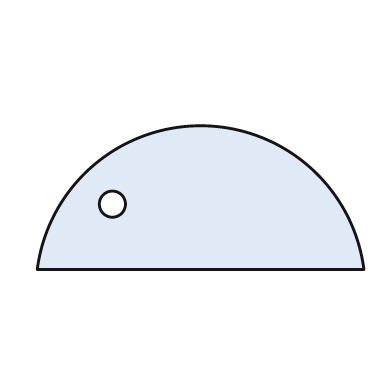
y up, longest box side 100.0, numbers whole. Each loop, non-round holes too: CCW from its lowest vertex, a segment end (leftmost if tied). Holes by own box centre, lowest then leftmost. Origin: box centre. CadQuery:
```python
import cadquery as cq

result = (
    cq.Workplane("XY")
    .moveTo(-50.0, -22.0)
    .lineTo(50.0, -22.0)
    .threePointArc((0.0, 22.0), (-50.0, -22.0))
    .close()
    .moveTo(-27.0, -2.0)
    .circle(4.0)
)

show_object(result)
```